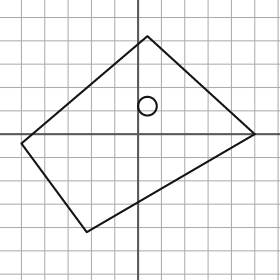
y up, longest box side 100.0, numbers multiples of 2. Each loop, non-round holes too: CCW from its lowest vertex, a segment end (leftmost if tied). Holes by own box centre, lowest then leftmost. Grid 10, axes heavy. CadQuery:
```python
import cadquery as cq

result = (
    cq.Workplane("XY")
    .moveTo(-22.0, -42.0)
    .lineTo(50.0, 0.0)
    .lineTo(4.0, 42.0)
    .lineTo(-50.0, -4.0)
    .close()
    .moveTo(4.0, 12.0)
    .circle(4.0)
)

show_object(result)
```